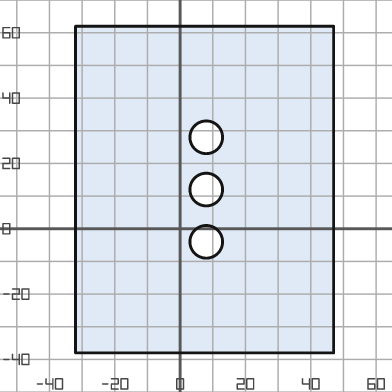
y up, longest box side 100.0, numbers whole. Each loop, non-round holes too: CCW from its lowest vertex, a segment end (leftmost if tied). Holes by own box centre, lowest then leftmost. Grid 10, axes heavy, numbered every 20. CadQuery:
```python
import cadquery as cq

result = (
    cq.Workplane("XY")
    .moveTo(-32.0, -38.0)
    .lineTo(47.0, -38.0)
    .lineTo(47.0, 62.0)
    .lineTo(-32.0, 62.0)
    .close()
    .moveTo(8.0, -4.0)
    .circle(5.0)
    .moveTo(8.0, 12.0)
    .circle(5.0)
    .moveTo(8.0, 28.0)
    .circle(5.0)
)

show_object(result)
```